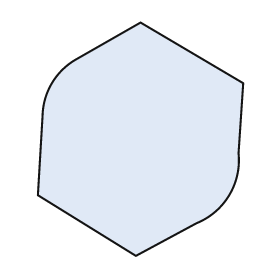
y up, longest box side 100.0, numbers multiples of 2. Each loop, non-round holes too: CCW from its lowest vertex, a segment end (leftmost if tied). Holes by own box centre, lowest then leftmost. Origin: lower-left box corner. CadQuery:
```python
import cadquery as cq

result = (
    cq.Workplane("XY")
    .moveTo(42.0, 0.0)
    .lineTo(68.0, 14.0)
    .threePointArc((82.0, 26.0), (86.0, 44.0))
    .lineTo(88.0, 74.0)
    .lineTo(44.0, 100.0)
    .lineTo(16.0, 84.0)
    .threePointArc((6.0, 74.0), (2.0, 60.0))
    .lineTo(0.0, 26.0)
    .close()
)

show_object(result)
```